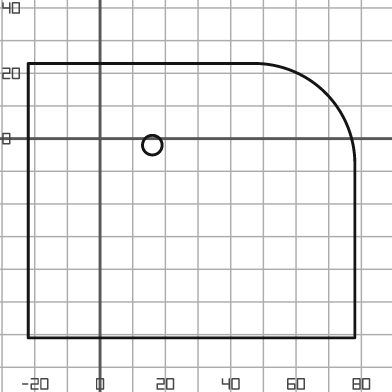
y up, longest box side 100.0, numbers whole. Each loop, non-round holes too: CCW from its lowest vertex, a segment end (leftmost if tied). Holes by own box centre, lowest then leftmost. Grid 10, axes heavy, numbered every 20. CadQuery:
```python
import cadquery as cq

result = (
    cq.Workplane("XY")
    .moveTo(-22.0, -61.0)
    .lineTo(78.0, -61.0)
    .lineTo(78.0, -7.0)
    .threePointArc((69.0, 14.0), (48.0, 23.0))
    .lineTo(-22.0, 23.0)
    .close()
    .moveTo(16.0, -2.0)
    .circle(3.0)
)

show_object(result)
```